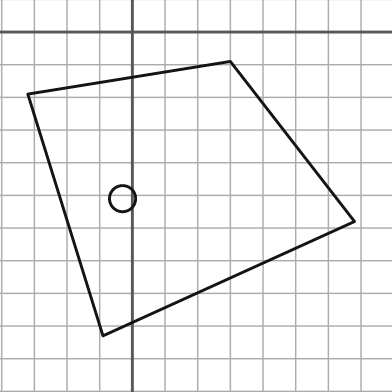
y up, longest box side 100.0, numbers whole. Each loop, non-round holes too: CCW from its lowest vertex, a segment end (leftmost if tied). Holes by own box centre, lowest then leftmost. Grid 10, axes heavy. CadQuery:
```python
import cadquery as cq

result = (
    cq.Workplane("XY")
    .moveTo(-9.0, -93.0)
    .lineTo(68.0, -58.0)
    .lineTo(30.0, -9.0)
    .lineTo(-32.0, -19.0)
    .close()
    .moveTo(-3.0, -51.0)
    .circle(4.0)
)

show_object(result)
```